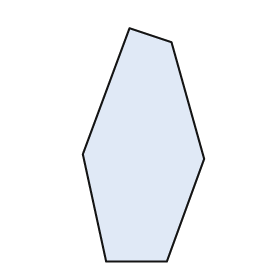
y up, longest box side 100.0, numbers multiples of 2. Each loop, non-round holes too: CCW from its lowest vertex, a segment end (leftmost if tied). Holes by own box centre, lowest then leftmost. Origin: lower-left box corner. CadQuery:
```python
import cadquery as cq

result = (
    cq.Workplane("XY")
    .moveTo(10.0, 0.0)
    .lineTo(36.0, 0.0)
    .lineTo(52.0, 44.0)
    .lineTo(38.0, 94.0)
    .lineTo(20.0, 100.0)
    .lineTo(0.0, 46.0)
    .close()
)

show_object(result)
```